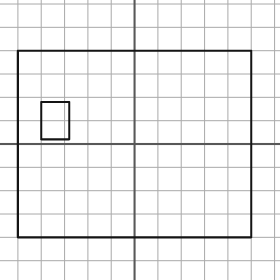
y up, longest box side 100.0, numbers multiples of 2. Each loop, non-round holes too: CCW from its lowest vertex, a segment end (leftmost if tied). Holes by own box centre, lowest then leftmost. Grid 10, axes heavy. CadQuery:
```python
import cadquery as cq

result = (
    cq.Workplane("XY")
    .moveTo(-50.0, -40.0)
    .lineTo(50.0, -40.0)
    .lineTo(50.0, 40.0)
    .lineTo(-50.0, 40.0)
    .close()
    .moveTo(-40.0, 2.0)
    .lineTo(-28.0, 2.0)
    .lineTo(-28.0, 18.0)
    .lineTo(-40.0, 18.0)
    .close()
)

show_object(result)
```